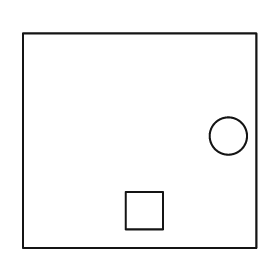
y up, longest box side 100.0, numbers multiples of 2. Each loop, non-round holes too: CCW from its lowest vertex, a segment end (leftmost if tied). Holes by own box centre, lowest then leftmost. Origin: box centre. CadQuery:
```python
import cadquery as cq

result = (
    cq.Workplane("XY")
    .moveTo(-50.0, -46.0)
    .lineTo(50.0, -46.0)
    .lineTo(50.0, 46.0)
    .lineTo(-50.0, 46.0)
    .close()
    .moveTo(-6.0, -38.0)
    .lineTo(10.0, -38.0)
    .lineTo(10.0, -22.0)
    .lineTo(-6.0, -22.0)
    .close()
    .moveTo(38.0, 2.0)
    .circle(8.0)
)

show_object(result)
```